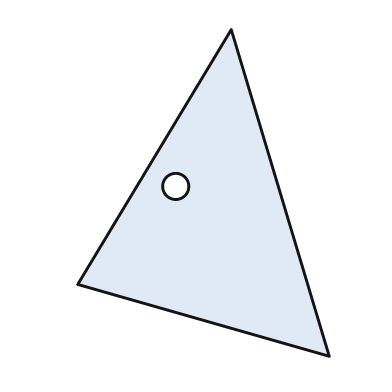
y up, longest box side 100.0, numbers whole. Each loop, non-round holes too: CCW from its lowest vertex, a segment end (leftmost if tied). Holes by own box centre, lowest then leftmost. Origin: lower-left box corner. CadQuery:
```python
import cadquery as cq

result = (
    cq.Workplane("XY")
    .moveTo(77.0, 0.0)
    .lineTo(47.0, 100.0)
    .lineTo(0.0, 22.0)
    .close()
    .moveTo(30.0, 52.0)
    .circle(4.0)
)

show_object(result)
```